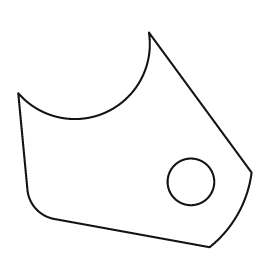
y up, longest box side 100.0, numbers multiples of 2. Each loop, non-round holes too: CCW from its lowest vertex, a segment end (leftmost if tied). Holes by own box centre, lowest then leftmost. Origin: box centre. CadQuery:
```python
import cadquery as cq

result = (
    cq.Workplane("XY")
    .moveTo(32.0, -46.0)
    .threePointArc((44.0, -32.0), (50.0, -14.0))
    .lineTo(6.0, 46.0)
    .threePointArc((-12.0, 12.0), (-50.0, 20.0))
    .lineTo(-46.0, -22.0)
    .threePointArc((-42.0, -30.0), (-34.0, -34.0))
    .close()
    .moveTo(24.0, -18.0)
    .circle(10.0)
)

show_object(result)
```